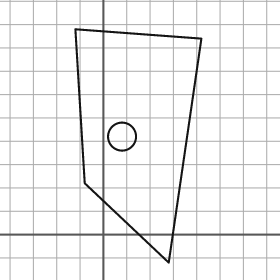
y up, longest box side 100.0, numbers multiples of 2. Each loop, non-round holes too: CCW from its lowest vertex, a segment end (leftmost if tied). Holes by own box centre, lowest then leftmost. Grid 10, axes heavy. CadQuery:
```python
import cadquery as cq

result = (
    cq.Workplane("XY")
    .moveTo(28.0, -12.0)
    .lineTo(42.0, 84.0)
    .lineTo(-12.0, 88.0)
    .lineTo(-8.0, 22.0)
    .close()
    .moveTo(8.0, 42.0)
    .circle(6.0)
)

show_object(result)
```